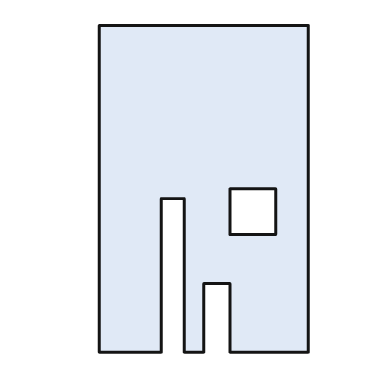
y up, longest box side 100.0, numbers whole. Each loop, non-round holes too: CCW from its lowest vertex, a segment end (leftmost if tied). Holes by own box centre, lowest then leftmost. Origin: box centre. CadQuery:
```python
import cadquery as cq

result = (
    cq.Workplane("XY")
    .moveTo(-32.0, -50.0)
    .lineTo(-13.0, -50.0)
    .lineTo(-13.0, -3.0)
    .lineTo(-6.0, -3.0)
    .lineTo(-6.0, -50.0)
    .lineTo(0.0, -50.0)
    .lineTo(0.0, -29.0)
    .lineTo(8.0, -29.0)
    .lineTo(8.0, -50.0)
    .lineTo(32.0, -50.0)
    .lineTo(32.0, 50.0)
    .lineTo(-32.0, 50.0)
    .close()
    .moveTo(8.0, -14.0)
    .lineTo(22.0, -14.0)
    .lineTo(22.0, 0.0)
    .lineTo(8.0, 0.0)
    .close()
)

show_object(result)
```